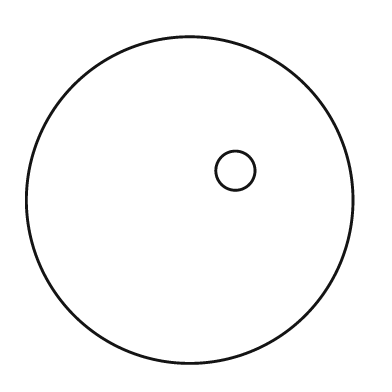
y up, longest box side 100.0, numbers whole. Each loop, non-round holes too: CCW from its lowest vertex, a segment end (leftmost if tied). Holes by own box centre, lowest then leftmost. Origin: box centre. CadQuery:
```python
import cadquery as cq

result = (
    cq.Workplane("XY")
    .moveTo(0.0, 0.0)
    .circle(50.0)
    .moveTo(14.0, 9.0)
    .circle(6.0)
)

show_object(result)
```